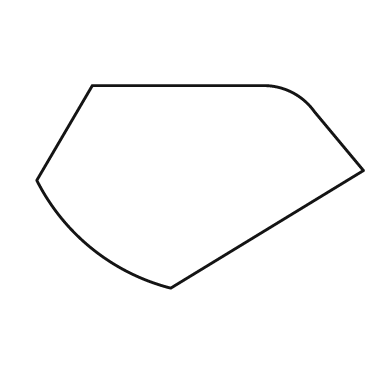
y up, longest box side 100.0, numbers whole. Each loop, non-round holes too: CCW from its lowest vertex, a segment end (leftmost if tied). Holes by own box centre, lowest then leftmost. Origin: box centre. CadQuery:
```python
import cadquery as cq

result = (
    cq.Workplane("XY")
    .moveTo(-9.0, -31.0)
    .lineTo(50.0, 5.0)
    .lineTo(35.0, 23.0)
    .threePointArc((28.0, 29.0), (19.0, 31.0))
    .lineTo(-33.0, 31.0)
    .lineTo(-50.0, 2.0)
    .threePointArc((-33.0, -19.0), (-9.0, -31.0))
    .close()
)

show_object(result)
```